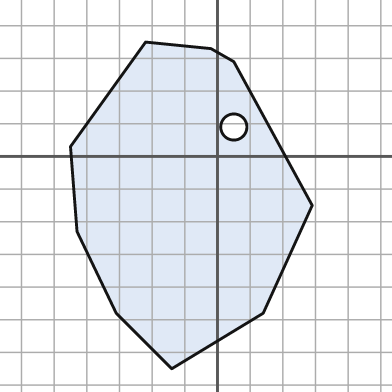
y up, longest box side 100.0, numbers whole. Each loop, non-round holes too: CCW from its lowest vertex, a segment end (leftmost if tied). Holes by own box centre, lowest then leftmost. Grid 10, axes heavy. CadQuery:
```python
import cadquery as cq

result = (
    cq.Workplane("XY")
    .moveTo(-14.0, -65.0)
    .lineTo(14.0, -48.0)
    .lineTo(29.0, -15.0)
    .lineTo(5.0, 29.0)
    .lineTo(-2.0, 33.0)
    .lineTo(-22.0, 35.0)
    .lineTo(-45.0, 3.0)
    .lineTo(-43.0, -23.0)
    .lineTo(-31.0, -48.0)
    .close()
    .moveTo(5.0, 9.0)
    .circle(4.0)
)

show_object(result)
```